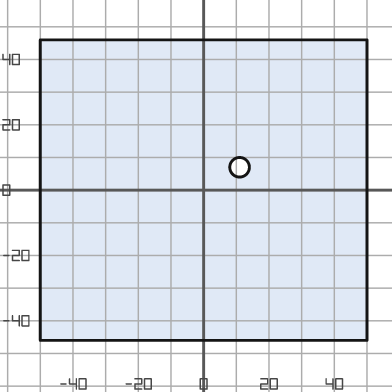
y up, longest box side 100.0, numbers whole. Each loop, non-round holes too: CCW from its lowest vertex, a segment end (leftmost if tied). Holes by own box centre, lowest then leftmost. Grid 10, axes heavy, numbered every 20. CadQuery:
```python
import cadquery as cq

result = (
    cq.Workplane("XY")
    .moveTo(-50.0, -46.0)
    .lineTo(50.0, -46.0)
    .lineTo(50.0, 46.0)
    .lineTo(-50.0, 46.0)
    .close()
    .moveTo(11.0, 7.0)
    .circle(3.0)
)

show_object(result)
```